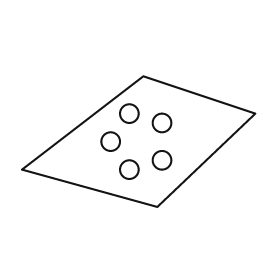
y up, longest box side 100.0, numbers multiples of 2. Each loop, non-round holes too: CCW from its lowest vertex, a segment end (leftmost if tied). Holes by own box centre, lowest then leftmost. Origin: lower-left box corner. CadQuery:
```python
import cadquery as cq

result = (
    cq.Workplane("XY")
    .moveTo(58.0, 0.0)
    .lineTo(100.0, 40.0)
    .lineTo(52.0, 56.0)
    .lineTo(0.0, 16.0)
    .close()
    .moveTo(46.0, 16.0)
    .circle(4.0)
    .moveTo(60.0, 20.0)
    .circle(4.0)
    .moveTo(38.0, 28.0)
    .circle(4.0)
    .moveTo(60.0, 36.0)
    .circle(4.0)
    .moveTo(46.0, 40.0)
    .circle(4.0)
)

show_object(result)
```